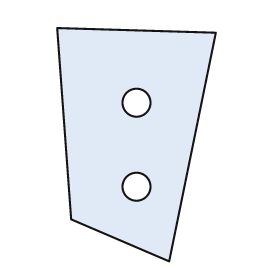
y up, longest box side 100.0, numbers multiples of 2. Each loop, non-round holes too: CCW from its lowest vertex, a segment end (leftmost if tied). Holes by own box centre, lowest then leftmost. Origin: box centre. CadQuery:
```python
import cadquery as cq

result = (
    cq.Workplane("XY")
    .moveTo(14.0, -50.0)
    .lineTo(34.0, 48.0)
    .lineTo(-34.0, 50.0)
    .lineTo(-28.0, -32.0)
    .close()
    .moveTo(0.0, -18.0)
    .circle(6.0)
    .moveTo(0.0, 18.0)
    .circle(6.0)
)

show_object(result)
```